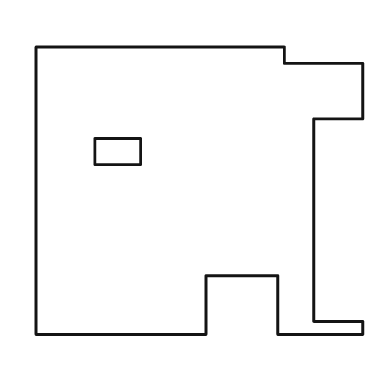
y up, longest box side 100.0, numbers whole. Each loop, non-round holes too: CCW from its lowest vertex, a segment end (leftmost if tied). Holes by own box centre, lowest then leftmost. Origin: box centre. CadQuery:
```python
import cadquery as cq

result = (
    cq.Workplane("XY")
    .moveTo(-50.0, -44.0)
    .lineTo(2.0, -44.0)
    .lineTo(2.0, -26.0)
    .lineTo(24.0, -26.0)
    .lineTo(24.0, -44.0)
    .lineTo(50.0, -44.0)
    .lineTo(50.0, -40.0)
    .lineTo(35.0, -40.0)
    .lineTo(35.0, 22.0)
    .lineTo(50.0, 22.0)
    .lineTo(50.0, 39.0)
    .lineTo(26.0, 39.0)
    .lineTo(26.0, 44.0)
    .lineTo(-50.0, 44.0)
    .close()
    .moveTo(-32.0, 8.0)
    .lineTo(-18.0, 8.0)
    .lineTo(-18.0, 16.0)
    .lineTo(-32.0, 16.0)
    .close()
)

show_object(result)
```